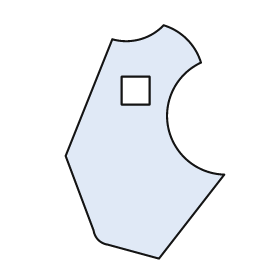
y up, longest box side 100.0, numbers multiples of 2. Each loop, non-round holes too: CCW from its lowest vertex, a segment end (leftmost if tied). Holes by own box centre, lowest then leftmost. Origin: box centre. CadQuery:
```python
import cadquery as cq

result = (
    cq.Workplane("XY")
    .moveTo(6.0, -50.0)
    .lineTo(34.0, -14.0)
    .threePointArc((10.0, 6.0), (24.0, 34.0))
    .threePointArc((18.0, 44.0), (8.0, 50.0))
    .threePointArc((-2.0, 44.0), (-14.0, 44.0))
    .lineTo(-34.0, -6.0)
    .lineTo(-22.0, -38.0)
    .threePointArc((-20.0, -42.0), (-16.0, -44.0))
    .close()
    .moveTo(-10.0, 16.0)
    .lineTo(2.0, 16.0)
    .lineTo(2.0, 28.0)
    .lineTo(-10.0, 28.0)
    .close()
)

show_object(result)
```